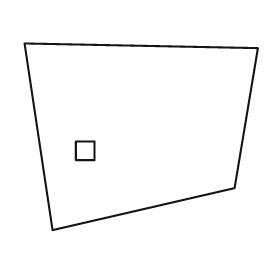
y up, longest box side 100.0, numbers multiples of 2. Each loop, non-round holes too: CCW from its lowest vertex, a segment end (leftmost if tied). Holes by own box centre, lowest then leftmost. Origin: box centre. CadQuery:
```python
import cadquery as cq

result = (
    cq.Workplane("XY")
    .moveTo(-38.0, -40.0)
    .lineTo(40.0, -22.0)
    .lineTo(50.0, 38.0)
    .lineTo(-50.0, 40.0)
    .close()
    .moveTo(-28.0, -10.0)
    .lineTo(-20.0, -10.0)
    .lineTo(-20.0, -2.0)
    .lineTo(-28.0, -2.0)
    .close()
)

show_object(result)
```